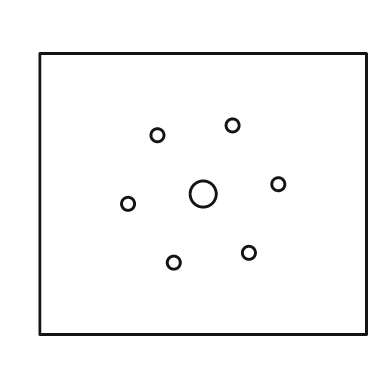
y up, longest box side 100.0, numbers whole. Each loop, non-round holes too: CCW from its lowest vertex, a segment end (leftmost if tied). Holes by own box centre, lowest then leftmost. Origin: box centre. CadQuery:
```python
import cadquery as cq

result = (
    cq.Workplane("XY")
    .moveTo(-50.0, -43.0)
    .lineTo(50.0, -43.0)
    .lineTo(50.0, 43.0)
    .lineTo(-50.0, 43.0)
    .close()
    .moveTo(-9.0, -21.0)
    .circle(2.0)
    .moveTo(14.0, -18.0)
    .circle(2.0)
    .moveTo(-23.0, -3.0)
    .circle(2.0)
    .moveTo(0.0, 0.0)
    .circle(4.0)
    .moveTo(23.0, 3.0)
    .circle(2.0)
    .moveTo(-14.0, 18.0)
    .circle(2.0)
    .moveTo(9.0, 21.0)
    .circle(2.0)
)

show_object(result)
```